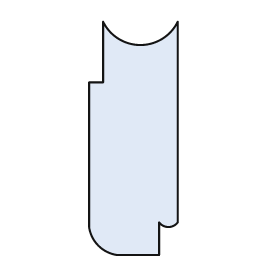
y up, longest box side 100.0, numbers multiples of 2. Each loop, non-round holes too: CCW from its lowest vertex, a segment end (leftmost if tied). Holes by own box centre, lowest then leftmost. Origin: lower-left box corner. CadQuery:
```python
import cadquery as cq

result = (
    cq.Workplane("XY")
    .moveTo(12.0, 0.0)
    .lineTo(30.0, 0.0)
    .lineTo(30.0, 14.0)
    .threePointArc((34.0, 12.0), (38.0, 14.0))
    .lineTo(38.0, 100.0)
    .threePointArc((22.0, 90.0), (6.0, 100.0))
    .lineTo(6.0, 74.0)
    .lineTo(0.0, 74.0)
    .lineTo(0.0, 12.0)
    .threePointArc((4.0, 4.0), (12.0, 0.0))
    .close()
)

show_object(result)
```